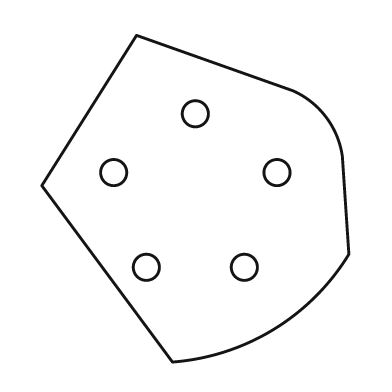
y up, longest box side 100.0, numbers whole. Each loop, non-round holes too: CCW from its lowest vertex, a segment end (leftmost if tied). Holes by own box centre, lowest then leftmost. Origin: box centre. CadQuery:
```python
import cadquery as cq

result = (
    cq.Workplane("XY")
    .moveTo(-7.0, -50.0)
    .threePointArc((24.0, -40.0), (47.0, -17.0))
    .lineTo(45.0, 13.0)
    .threePointArc((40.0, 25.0), (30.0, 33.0))
    .lineTo(-18.0, 50.0)
    .lineTo(-47.0, 4.0)
    .close()
    .moveTo(-15.0, -21.0)
    .circle(4.0)
    .moveTo(15.0, -21.0)
    .circle(4.0)
    .moveTo(-25.0, 8.0)
    .circle(4.0)
    .moveTo(25.0, 8.0)
    .circle(4.0)
    .moveTo(0.0, 26.0)
    .circle(4.0)
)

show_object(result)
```